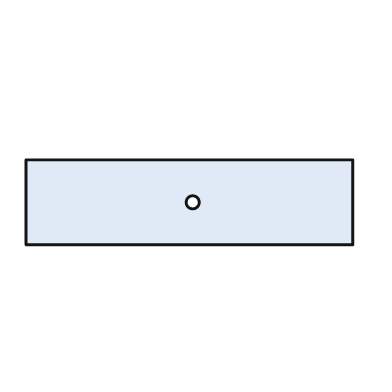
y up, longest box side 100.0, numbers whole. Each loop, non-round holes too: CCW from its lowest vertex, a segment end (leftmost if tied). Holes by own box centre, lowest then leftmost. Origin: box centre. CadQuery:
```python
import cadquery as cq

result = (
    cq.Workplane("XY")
    .moveTo(-50.0, -13.0)
    .lineTo(50.0, -13.0)
    .lineTo(50.0, 13.0)
    .lineTo(-50.0, 13.0)
    .close()
    .moveTo(1.0, 0.0)
    .circle(2.0)
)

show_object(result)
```